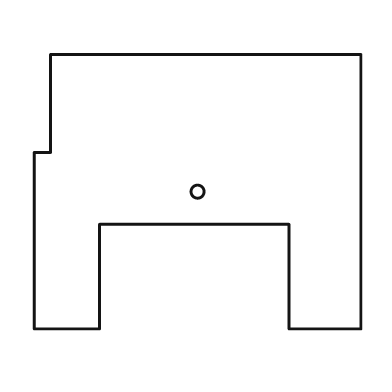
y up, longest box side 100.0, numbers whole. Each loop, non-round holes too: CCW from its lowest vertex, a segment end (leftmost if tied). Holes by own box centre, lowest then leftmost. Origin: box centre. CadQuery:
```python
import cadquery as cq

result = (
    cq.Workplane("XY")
    .moveTo(-50.0, -42.0)
    .lineTo(-30.0, -42.0)
    .lineTo(-30.0, -10.0)
    .lineTo(28.0, -10.0)
    .lineTo(28.0, -42.0)
    .lineTo(50.0, -42.0)
    .lineTo(50.0, 42.0)
    .lineTo(-45.0, 42.0)
    .lineTo(-45.0, 12.0)
    .lineTo(-50.0, 12.0)
    .close()
    .moveTo(0.0, 0.0)
    .circle(2.0)
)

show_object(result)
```